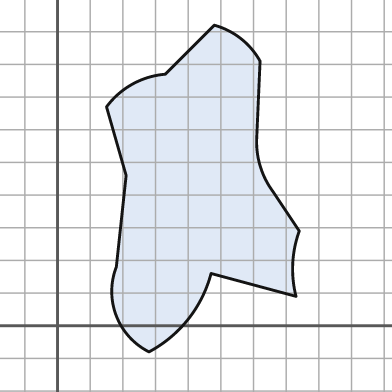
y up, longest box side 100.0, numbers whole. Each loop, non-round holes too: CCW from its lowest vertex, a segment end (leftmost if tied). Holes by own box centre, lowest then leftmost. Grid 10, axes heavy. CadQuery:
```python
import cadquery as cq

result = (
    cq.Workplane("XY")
    .moveTo(28.0, -8.0)
    .threePointArc((40.0, 2.0), (47.0, 16.0))
    .lineTo(73.0, 9.0)
    .threePointArc((72.0, 19.0), (74.0, 29.0))
    .lineTo(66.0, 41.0)
    .threePointArc((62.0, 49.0), (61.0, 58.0))
    .lineTo(62.0, 81.0)
    .threePointArc((56.0, 88.0), (48.0, 92.0))
    .lineTo(33.0, 77.0)
    .threePointArc((23.0, 74.0), (15.0, 67.0))
    .lineTo(21.0, 46.0)
    .lineTo(18.0, 18.0)
    .threePointArc((18.0, 3.0), (28.0, -8.0))
    .close()
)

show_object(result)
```